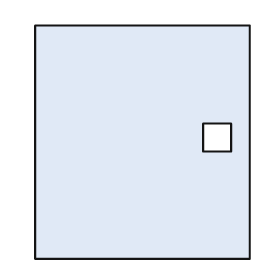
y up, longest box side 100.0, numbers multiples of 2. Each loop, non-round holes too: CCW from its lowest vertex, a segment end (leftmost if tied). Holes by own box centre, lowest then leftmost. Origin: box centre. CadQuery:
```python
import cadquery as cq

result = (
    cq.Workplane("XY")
    .moveTo(-46.0, -50.0)
    .lineTo(46.0, -50.0)
    .lineTo(46.0, 50.0)
    .lineTo(-46.0, 50.0)
    .close()
    .moveTo(26.0, -4.0)
    .lineTo(38.0, -4.0)
    .lineTo(38.0, 8.0)
    .lineTo(26.0, 8.0)
    .close()
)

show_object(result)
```